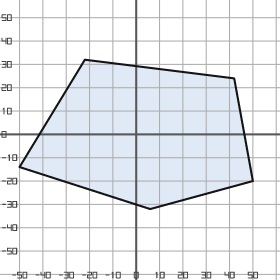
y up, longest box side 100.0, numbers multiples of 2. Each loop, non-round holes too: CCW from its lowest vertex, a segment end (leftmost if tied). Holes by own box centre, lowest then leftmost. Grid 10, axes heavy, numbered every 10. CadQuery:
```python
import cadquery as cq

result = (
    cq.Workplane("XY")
    .moveTo(6.0, -32.0)
    .lineTo(50.0, -20.0)
    .lineTo(42.0, 24.0)
    .lineTo(-22.0, 32.0)
    .lineTo(-50.0, -14.0)
    .close()
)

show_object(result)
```